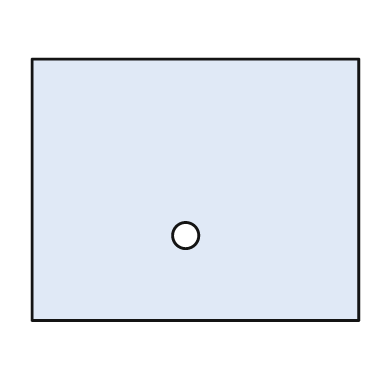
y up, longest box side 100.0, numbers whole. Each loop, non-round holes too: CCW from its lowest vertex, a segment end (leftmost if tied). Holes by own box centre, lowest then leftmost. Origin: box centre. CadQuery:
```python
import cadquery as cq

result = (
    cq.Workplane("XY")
    .moveTo(-50.0, -40.0)
    .lineTo(50.0, -40.0)
    .lineTo(50.0, 40.0)
    .lineTo(-50.0, 40.0)
    .close()
    .moveTo(-3.0, -14.0)
    .circle(4.0)
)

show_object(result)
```